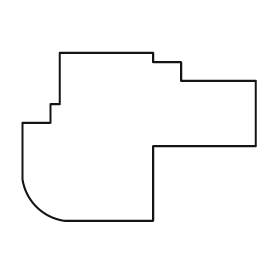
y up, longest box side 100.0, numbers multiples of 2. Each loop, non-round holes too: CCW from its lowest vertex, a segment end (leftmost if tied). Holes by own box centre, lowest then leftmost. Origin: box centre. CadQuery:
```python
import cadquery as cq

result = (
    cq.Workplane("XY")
    .moveTo(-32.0, -36.0)
    .lineTo(6.0, -36.0)
    .lineTo(6.0, -4.0)
    .lineTo(50.0, -4.0)
    .lineTo(50.0, 24.0)
    .lineTo(18.0, 24.0)
    .lineTo(18.0, 32.0)
    .lineTo(6.0, 32.0)
    .lineTo(6.0, 36.0)
    .lineTo(-34.0, 36.0)
    .lineTo(-34.0, 14.0)
    .lineTo(-38.0, 14.0)
    .lineTo(-38.0, 6.0)
    .lineTo(-50.0, 6.0)
    .lineTo(-50.0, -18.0)
    .threePointArc((-44.0, -30.0), (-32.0, -36.0))
    .close()
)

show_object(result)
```